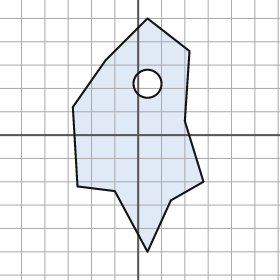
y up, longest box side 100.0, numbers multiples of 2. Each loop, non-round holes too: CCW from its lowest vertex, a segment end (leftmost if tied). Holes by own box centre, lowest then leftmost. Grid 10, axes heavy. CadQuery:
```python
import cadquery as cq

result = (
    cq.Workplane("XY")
    .moveTo(4.0, -50.0)
    .lineTo(14.0, -28.0)
    .lineTo(28.0, -20.0)
    .lineTo(20.0, 6.0)
    .lineTo(22.0, 36.0)
    .lineTo(4.0, 50.0)
    .lineTo(-14.0, 32.0)
    .lineTo(-28.0, 12.0)
    .lineTo(-26.0, -22.0)
    .lineTo(-10.0, -24.0)
    .close()
    .moveTo(4.0, 22.0)
    .circle(6.0)
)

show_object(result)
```